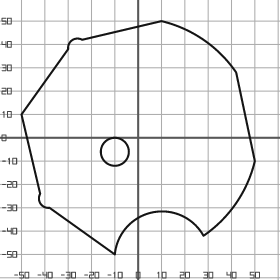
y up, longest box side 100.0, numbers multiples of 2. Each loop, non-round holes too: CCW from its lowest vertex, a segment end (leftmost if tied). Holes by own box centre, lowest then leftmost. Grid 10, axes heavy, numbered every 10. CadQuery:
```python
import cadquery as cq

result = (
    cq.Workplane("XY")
    .moveTo(-10.0, -50.0)
    .threePointArc((6.0, -32.0), (28.0, -42.0))
    .threePointArc((42.0, -28.0), (50.0, -10.0))
    .lineTo(42.0, 28.0)
    .threePointArc((28.0, 42.0), (10.0, 50.0))
    .lineTo(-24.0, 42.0)
    .threePointArc((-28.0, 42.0), (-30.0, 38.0))
    .lineTo(-50.0, 10.0)
    .lineTo(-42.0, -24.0)
    .threePointArc((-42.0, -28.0), (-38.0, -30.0))
    .close()
    .moveTo(-10.0, -6.0)
    .circle(6.0)
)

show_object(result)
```